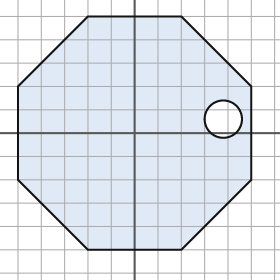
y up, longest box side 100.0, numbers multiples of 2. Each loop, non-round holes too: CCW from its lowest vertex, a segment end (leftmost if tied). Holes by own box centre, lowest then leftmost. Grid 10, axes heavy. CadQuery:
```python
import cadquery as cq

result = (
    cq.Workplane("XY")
    .moveTo(-20.0, -50.0)
    .lineTo(20.0, -50.0)
    .lineTo(50.0, -20.0)
    .lineTo(50.0, 20.0)
    .lineTo(20.0, 50.0)
    .lineTo(-20.0, 50.0)
    .lineTo(-50.0, 20.0)
    .lineTo(-50.0, -20.0)
    .close()
    .moveTo(38.0, 6.0)
    .circle(8.0)
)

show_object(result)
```